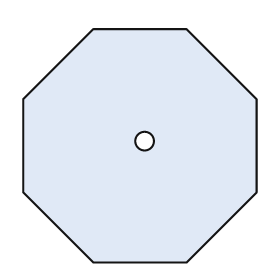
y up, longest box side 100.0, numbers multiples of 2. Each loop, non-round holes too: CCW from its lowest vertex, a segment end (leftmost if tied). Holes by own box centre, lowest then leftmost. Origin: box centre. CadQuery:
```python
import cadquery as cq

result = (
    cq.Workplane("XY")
    .moveTo(-20.0, -50.0)
    .lineTo(20.0, -50.0)
    .lineTo(50.0, -20.0)
    .lineTo(50.0, 20.0)
    .lineTo(20.0, 50.0)
    .lineTo(-20.0, 50.0)
    .lineTo(-50.0, 20.0)
    .lineTo(-50.0, -20.0)
    .close()
    .moveTo(2.0, 2.0)
    .circle(4.0)
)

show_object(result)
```